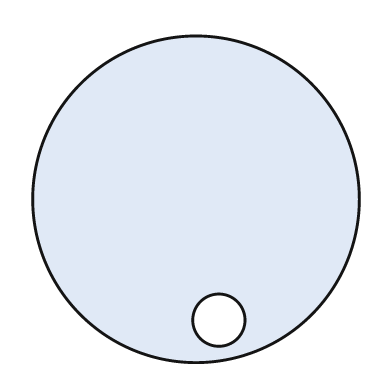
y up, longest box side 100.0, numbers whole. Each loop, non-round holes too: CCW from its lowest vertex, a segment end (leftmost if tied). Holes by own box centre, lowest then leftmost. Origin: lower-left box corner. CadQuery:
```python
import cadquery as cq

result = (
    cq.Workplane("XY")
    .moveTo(50.0, 50.0)
    .circle(50.0)
    .moveTo(57.0, 13.0)
    .circle(8.0)
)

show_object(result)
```